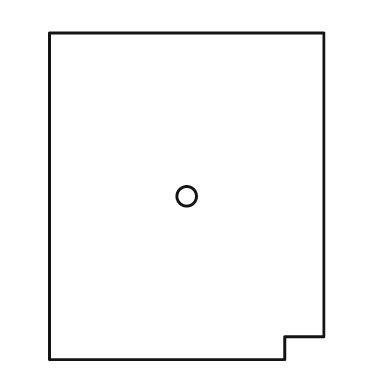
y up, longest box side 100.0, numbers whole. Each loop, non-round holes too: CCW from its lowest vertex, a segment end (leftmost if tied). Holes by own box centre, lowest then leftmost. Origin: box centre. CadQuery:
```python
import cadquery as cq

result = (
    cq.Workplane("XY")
    .moveTo(-42.0, -50.0)
    .lineTo(30.0, -50.0)
    .lineTo(30.0, -43.0)
    .lineTo(42.0, -43.0)
    .lineTo(42.0, 50.0)
    .lineTo(-42.0, 50.0)
    .close()
    .moveTo(0.0, 0.0)
    .circle(3.0)
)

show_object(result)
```